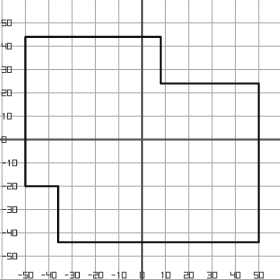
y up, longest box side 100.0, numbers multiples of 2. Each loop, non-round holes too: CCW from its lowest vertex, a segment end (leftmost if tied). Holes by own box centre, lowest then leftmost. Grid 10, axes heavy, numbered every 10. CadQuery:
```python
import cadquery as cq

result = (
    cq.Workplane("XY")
    .moveTo(-36.0, -44.0)
    .lineTo(50.0, -44.0)
    .lineTo(50.0, 24.0)
    .lineTo(8.0, 24.0)
    .lineTo(8.0, 44.0)
    .lineTo(-50.0, 44.0)
    .lineTo(-50.0, -20.0)
    .lineTo(-36.0, -20.0)
    .close()
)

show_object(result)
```